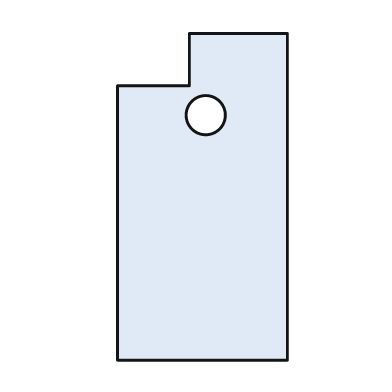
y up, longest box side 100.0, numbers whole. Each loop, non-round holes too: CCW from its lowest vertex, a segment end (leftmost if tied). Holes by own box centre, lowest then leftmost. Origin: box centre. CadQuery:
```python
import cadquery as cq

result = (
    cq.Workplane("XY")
    .moveTo(-26.0, -50.0)
    .lineTo(26.0, -50.0)
    .lineTo(26.0, 50.0)
    .lineTo(-4.0, 50.0)
    .lineTo(-4.0, 34.0)
    .lineTo(-26.0, 34.0)
    .close()
    .moveTo(1.0, 25.0)
    .circle(6.0)
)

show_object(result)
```